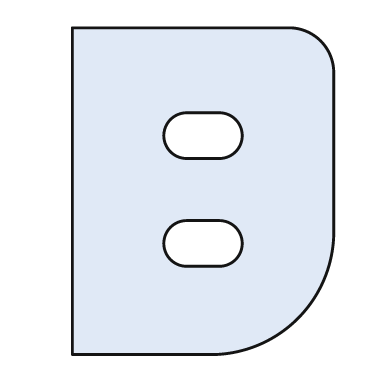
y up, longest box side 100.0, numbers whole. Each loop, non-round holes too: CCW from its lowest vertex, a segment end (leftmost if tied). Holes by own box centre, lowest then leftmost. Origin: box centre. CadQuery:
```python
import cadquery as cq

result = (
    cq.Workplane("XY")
    .moveTo(-40.0, -50.0)
    .lineTo(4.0, -50.0)
    .threePointArc((29.0, -39.0), (40.0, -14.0))
    .lineTo(40.0, 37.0)
    .threePointArc((36.0, 46.0), (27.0, 50.0))
    .lineTo(-40.0, 50.0)
    .close()
    .moveTo(-5.0, -23.0)
    .lineTo(5.0, -23.0)
    .threePointArc((12.0, -16.0), (5.0, -9.0))
    .lineTo(-5.0, -9.0)
    .threePointArc((-12.0, -16.0), (-5.0, -23.0))
    .close()
    .moveTo(-5.0, 10.0)
    .lineTo(5.0, 10.0)
    .threePointArc((12.0, 17.0), (5.0, 24.0))
    .lineTo(-5.0, 24.0)
    .threePointArc((-12.0, 17.0), (-5.0, 10.0))
    .close()
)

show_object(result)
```